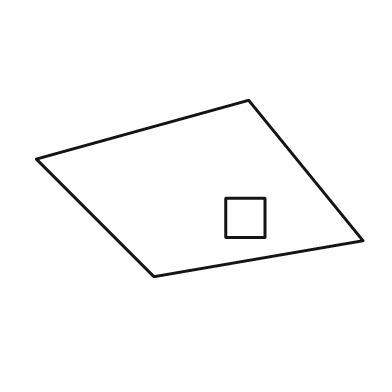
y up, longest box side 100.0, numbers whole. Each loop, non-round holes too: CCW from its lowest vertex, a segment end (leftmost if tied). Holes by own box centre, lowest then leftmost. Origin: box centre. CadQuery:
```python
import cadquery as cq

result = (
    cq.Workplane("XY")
    .moveTo(-14.0, -27.0)
    .lineTo(50.0, -16.0)
    .lineTo(15.0, 27.0)
    .lineTo(-50.0, 9.0)
    .close()
    .moveTo(8.0, -15.0)
    .lineTo(20.0, -15.0)
    .lineTo(20.0, -3.0)
    .lineTo(8.0, -3.0)
    .close()
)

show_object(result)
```